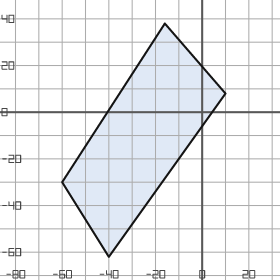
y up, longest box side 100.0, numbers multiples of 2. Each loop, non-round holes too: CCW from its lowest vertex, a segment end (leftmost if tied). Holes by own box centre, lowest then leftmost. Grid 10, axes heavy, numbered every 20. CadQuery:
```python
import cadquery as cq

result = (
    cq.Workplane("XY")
    .moveTo(-40.0, -62.0)
    .lineTo(10.0, 8.0)
    .lineTo(-16.0, 38.0)
    .lineTo(-60.0, -30.0)
    .close()
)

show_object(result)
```